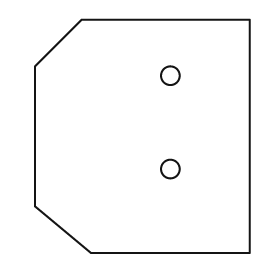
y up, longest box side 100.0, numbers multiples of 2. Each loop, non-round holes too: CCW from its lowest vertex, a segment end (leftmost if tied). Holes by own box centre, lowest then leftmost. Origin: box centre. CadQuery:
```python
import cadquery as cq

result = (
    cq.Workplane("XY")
    .moveTo(-22.0, -50.0)
    .lineTo(46.0, -50.0)
    .lineTo(46.0, 50.0)
    .lineTo(-26.0, 50.0)
    .lineTo(-46.0, 30.0)
    .lineTo(-46.0, -30.0)
    .close()
    .moveTo(12.0, -14.0)
    .circle(4.0)
    .moveTo(12.0, 26.0)
    .circle(4.0)
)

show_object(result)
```